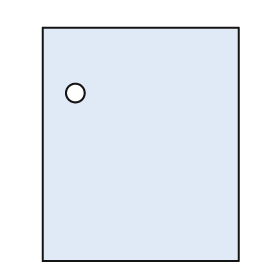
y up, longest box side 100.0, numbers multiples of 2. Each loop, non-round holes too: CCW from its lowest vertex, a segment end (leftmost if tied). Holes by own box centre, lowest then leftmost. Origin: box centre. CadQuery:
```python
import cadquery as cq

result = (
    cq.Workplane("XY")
    .moveTo(-42.0, -50.0)
    .lineTo(42.0, -50.0)
    .lineTo(42.0, 50.0)
    .lineTo(-42.0, 50.0)
    .close()
    .moveTo(-28.0, 22.0)
    .circle(4.0)
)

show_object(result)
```